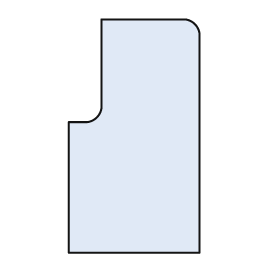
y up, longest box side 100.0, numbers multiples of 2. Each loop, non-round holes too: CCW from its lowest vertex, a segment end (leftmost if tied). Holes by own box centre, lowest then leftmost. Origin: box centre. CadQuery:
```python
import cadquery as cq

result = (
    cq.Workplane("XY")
    .moveTo(-28.0, -50.0)
    .lineTo(28.0, -50.0)
    .lineTo(28.0, 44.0)
    .threePointArc((26.0, 48.0), (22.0, 50.0))
    .lineTo(-14.0, 50.0)
    .lineTo(-14.0, 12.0)
    .threePointArc((-16.0, 8.0), (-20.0, 6.0))
    .lineTo(-28.0, 6.0)
    .close()
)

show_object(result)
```